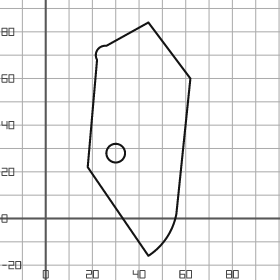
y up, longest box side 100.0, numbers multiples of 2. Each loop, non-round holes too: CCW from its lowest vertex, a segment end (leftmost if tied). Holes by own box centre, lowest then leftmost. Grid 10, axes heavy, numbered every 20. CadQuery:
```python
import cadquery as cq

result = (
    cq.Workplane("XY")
    .moveTo(44.0, -16.0)
    .threePointArc((52.0, -8.0), (56.0, 2.0))
    .lineTo(62.0, 60.0)
    .lineTo(44.0, 84.0)
    .lineTo(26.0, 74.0)
    .threePointArc((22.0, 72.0), (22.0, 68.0))
    .lineTo(18.0, 22.0)
    .close()
    .moveTo(30.0, 28.0)
    .circle(4.0)
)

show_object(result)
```